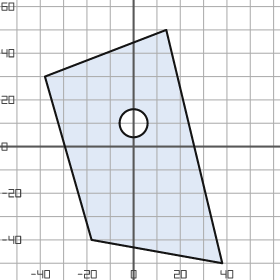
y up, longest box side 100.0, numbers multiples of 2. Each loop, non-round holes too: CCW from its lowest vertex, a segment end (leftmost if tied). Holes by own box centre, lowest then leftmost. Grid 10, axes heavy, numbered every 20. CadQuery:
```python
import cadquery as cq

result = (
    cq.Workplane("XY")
    .moveTo(38.0, -50.0)
    .lineTo(14.0, 50.0)
    .lineTo(-38.0, 30.0)
    .lineTo(-18.0, -40.0)
    .close()
    .moveTo(0.0, 10.0)
    .circle(6.0)
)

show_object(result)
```